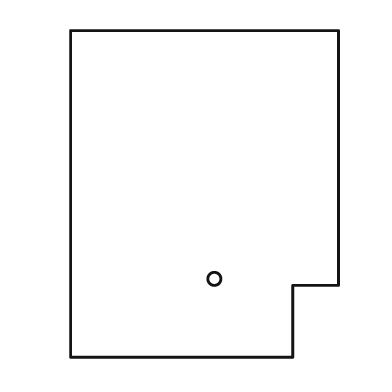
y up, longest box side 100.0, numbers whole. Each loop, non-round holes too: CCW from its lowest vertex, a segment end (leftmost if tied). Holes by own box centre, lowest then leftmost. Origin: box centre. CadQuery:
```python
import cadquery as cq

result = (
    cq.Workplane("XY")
    .moveTo(-41.0, -50.0)
    .lineTo(27.0, -50.0)
    .lineTo(27.0, -28.0)
    .lineTo(41.0, -28.0)
    .lineTo(41.0, 50.0)
    .lineTo(-41.0, 50.0)
    .close()
    .moveTo(3.0, -26.0)
    .circle(2.0)
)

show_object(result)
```